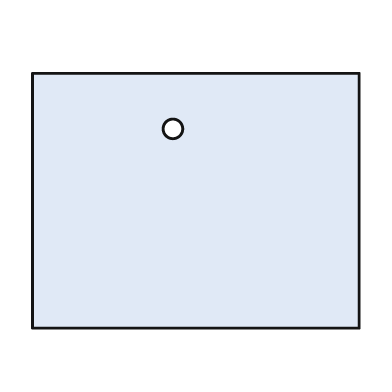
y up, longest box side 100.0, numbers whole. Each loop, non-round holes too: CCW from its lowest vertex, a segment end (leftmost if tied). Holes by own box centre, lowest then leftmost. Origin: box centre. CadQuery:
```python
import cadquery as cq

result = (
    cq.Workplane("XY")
    .moveTo(-50.0, -39.0)
    .lineTo(50.0, -39.0)
    .lineTo(50.0, 39.0)
    .lineTo(-50.0, 39.0)
    .close()
    .moveTo(-7.0, 22.0)
    .circle(3.0)
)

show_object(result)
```